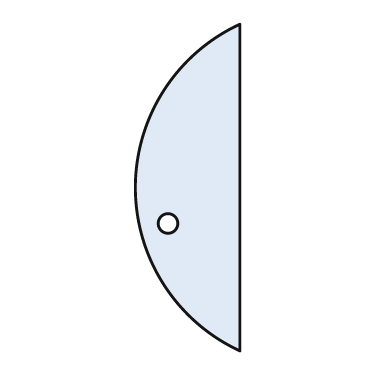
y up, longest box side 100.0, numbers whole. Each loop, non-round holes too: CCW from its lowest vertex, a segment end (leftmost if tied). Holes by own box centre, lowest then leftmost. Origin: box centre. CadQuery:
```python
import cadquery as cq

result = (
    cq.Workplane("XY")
    .moveTo(16.0, -50.0)
    .lineTo(16.0, 50.0)
    .threePointArc((-16.0, 0.0), (16.0, -50.0))
    .close()
    .moveTo(-6.0, -11.0)
    .circle(3.0)
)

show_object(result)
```